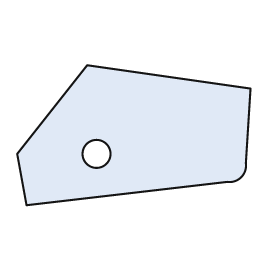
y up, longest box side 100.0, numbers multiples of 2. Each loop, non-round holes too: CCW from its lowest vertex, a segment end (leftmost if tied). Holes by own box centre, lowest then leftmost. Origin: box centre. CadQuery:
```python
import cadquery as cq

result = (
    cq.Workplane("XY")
    .moveTo(-46.0, -30.0)
    .lineTo(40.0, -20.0)
    .threePointArc((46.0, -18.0), (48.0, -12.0))
    .lineTo(50.0, 20.0)
    .lineTo(-20.0, 30.0)
    .lineTo(-50.0, -8.0)
    .close()
    .moveTo(-16.0, -8.0)
    .circle(6.0)
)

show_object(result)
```